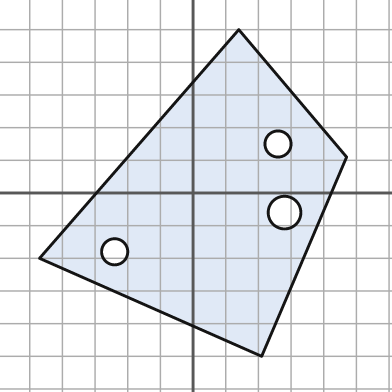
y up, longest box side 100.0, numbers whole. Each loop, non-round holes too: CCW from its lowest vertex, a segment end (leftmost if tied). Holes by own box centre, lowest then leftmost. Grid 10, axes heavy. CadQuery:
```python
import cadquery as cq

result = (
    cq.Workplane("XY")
    .moveTo(21.0, -50.0)
    .lineTo(47.0, 11.0)
    .lineTo(14.0, 50.0)
    .lineTo(-47.0, -20.0)
    .close()
    .moveTo(-24.0, -18.0)
    .circle(4.0)
    .moveTo(28.0, -6.0)
    .circle(5.0)
    .moveTo(26.0, 15.0)
    .circle(4.0)
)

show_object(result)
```